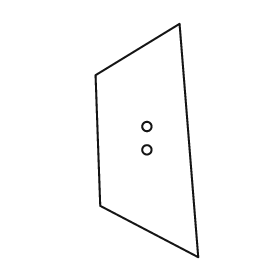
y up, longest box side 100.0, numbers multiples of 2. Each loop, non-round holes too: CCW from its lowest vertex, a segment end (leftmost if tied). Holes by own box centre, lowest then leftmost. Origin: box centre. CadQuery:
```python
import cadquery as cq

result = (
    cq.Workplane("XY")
    .moveTo(22.0, -50.0)
    .lineTo(14.0, 50.0)
    .lineTo(-22.0, 28.0)
    .lineTo(-20.0, -28.0)
    .close()
    .moveTo(0.0, -4.0)
    .circle(2.0)
    .moveTo(0.0, 6.0)
    .circle(2.0)
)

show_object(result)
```